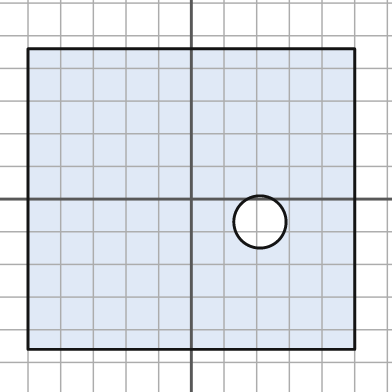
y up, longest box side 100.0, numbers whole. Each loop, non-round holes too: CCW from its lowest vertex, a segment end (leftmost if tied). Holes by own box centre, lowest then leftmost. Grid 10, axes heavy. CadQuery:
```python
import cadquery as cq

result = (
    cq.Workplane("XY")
    .moveTo(-50.0, -46.0)
    .lineTo(50.0, -46.0)
    .lineTo(50.0, 46.0)
    .lineTo(-50.0, 46.0)
    .close()
    .moveTo(21.0, -7.0)
    .circle(8.0)
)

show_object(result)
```